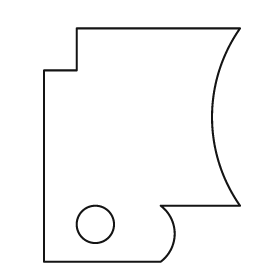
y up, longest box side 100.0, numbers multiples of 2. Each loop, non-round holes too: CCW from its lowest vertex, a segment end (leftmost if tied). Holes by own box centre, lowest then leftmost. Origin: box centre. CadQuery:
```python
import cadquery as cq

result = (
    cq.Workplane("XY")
    .moveTo(-42.0, -50.0)
    .lineTo(8.0, -50.0)
    .threePointArc((14.0, -38.0), (8.0, -26.0))
    .lineTo(42.0, -26.0)
    .threePointArc((30.0, 12.0), (42.0, 50.0))
    .lineTo(-28.0, 50.0)
    .lineTo(-28.0, 32.0)
    .lineTo(-42.0, 32.0)
    .close()
    .moveTo(-20.0, -34.0)
    .circle(8.0)
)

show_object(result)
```